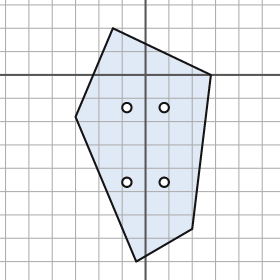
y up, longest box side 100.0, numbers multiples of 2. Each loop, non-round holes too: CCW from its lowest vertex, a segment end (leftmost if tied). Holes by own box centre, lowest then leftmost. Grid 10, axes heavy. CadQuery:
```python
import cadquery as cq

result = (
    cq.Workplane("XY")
    .moveTo(-4.0, -80.0)
    .lineTo(20.0, -66.0)
    .lineTo(28.0, 0.0)
    .lineTo(-14.0, 20.0)
    .lineTo(-30.0, -18.0)
    .close()
    .moveTo(-8.0, -46.0)
    .circle(2.0)
    .moveTo(8.0, -46.0)
    .circle(2.0)
    .moveTo(-8.0, -14.0)
    .circle(2.0)
    .moveTo(8.0, -14.0)
    .circle(2.0)
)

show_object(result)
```